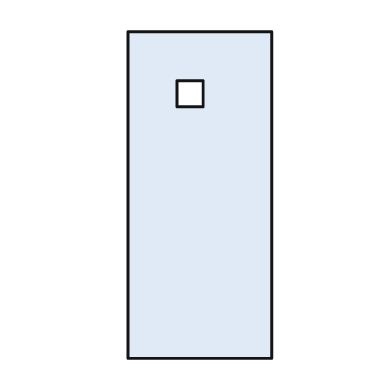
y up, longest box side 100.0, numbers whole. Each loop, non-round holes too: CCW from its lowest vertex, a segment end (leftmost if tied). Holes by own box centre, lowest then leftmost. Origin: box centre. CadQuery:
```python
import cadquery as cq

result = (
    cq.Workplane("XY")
    .moveTo(-22.0, -50.0)
    .lineTo(22.0, -50.0)
    .lineTo(22.0, 50.0)
    .lineTo(-22.0, 50.0)
    .close()
    .moveTo(-7.0, 27.0)
    .lineTo(1.0, 27.0)
    .lineTo(1.0, 35.0)
    .lineTo(-7.0, 35.0)
    .close()
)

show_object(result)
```